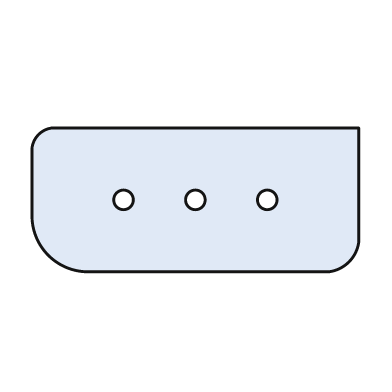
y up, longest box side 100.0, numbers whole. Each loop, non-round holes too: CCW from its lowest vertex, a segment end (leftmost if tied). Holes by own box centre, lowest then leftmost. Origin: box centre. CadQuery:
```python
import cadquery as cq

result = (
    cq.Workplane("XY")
    .moveTo(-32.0, -22.0)
    .lineTo(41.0, -22.0)
    .threePointArc((47.0, -19.0), (50.0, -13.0))
    .lineTo(50.0, 22.0)
    .lineTo(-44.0, 22.0)
    .threePointArc((-48.0, 20.0), (-50.0, 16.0))
    .lineTo(-50.0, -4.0)
    .threePointArc((-45.0, -17.0), (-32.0, -22.0))
    .close()
    .moveTo(-22.0, 0.0)
    .circle(3.0)
    .moveTo(0.0, 0.0)
    .circle(3.0)
    .moveTo(22.0, 0.0)
    .circle(3.0)
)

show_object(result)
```